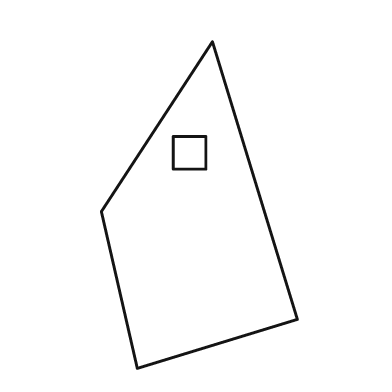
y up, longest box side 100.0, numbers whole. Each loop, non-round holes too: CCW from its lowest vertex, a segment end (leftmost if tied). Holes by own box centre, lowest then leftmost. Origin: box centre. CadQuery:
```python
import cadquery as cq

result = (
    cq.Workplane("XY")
    .moveTo(-19.0, -50.0)
    .lineTo(30.0, -35.0)
    .lineTo(4.0, 50.0)
    .lineTo(-30.0, -2.0)
    .close()
    .moveTo(-8.0, 11.0)
    .lineTo(2.0, 11.0)
    .lineTo(2.0, 21.0)
    .lineTo(-8.0, 21.0)
    .close()
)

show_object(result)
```